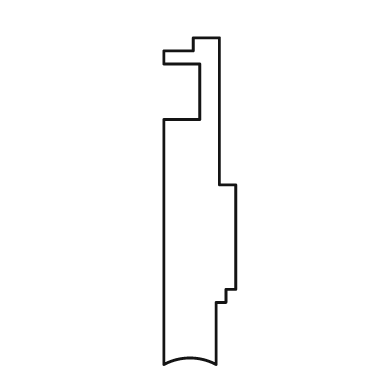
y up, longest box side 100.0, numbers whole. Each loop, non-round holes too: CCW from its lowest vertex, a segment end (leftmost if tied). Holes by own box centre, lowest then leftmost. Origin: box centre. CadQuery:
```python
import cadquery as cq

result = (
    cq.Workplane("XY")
    .moveTo(-11.0, -50.0)
    .threePointArc((-3.0, -48.0), (5.0, -50.0))
    .lineTo(5.0, -31.0)
    .lineTo(8.0, -31.0)
    .lineTo(8.0, -27.0)
    .lineTo(11.0, -27.0)
    .lineTo(11.0, 5.0)
    .lineTo(6.0, 5.0)
    .lineTo(6.0, 50.0)
    .lineTo(-2.0, 50.0)
    .lineTo(-2.0, 46.0)
    .lineTo(-11.0, 46.0)
    .lineTo(-11.0, 42.0)
    .lineTo(0.0, 42.0)
    .lineTo(0.0, 25.0)
    .lineTo(-11.0, 25.0)
    .close()
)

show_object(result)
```